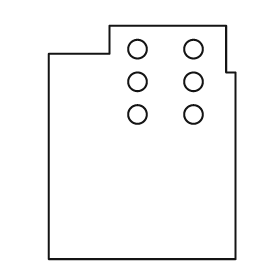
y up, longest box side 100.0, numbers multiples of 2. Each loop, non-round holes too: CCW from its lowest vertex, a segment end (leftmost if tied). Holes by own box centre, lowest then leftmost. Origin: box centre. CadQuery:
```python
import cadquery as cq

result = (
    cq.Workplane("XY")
    .moveTo(-40.0, -50.0)
    .lineTo(40.0, -50.0)
    .lineTo(40.0, 30.0)
    .lineTo(36.0, 30.0)
    .lineTo(36.0, 50.0)
    .lineTo(-14.0, 50.0)
    .lineTo(-14.0, 38.0)
    .lineTo(-40.0, 38.0)
    .close()
    .moveTo(-2.0, 12.0)
    .circle(4.0)
    .moveTo(22.0, 12.0)
    .circle(4.0)
    .moveTo(-2.0, 26.0)
    .circle(4.0)
    .moveTo(22.0, 26.0)
    .circle(4.0)
    .moveTo(-2.0, 40.0)
    .circle(4.0)
    .moveTo(22.0, 40.0)
    .circle(4.0)
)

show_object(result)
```